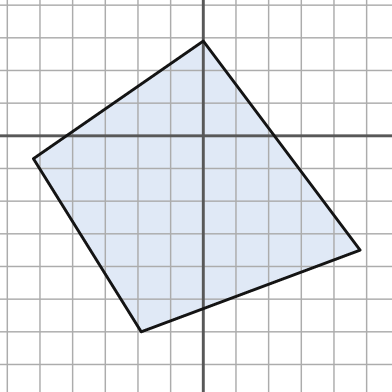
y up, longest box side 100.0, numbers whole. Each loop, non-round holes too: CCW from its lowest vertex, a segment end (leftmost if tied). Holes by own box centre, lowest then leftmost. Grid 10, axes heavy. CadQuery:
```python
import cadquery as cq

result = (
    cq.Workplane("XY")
    .moveTo(-19.0, -60.0)
    .lineTo(48.0, -35.0)
    .lineTo(0.0, 29.0)
    .lineTo(-52.0, -7.0)
    .close()
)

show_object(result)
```